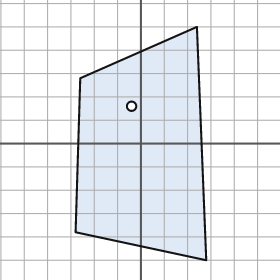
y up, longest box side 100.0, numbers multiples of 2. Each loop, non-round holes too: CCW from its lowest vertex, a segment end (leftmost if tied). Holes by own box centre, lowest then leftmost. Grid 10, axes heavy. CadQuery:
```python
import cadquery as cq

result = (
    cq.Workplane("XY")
    .moveTo(28.0, -50.0)
    .lineTo(24.0, 50.0)
    .lineTo(-26.0, 28.0)
    .lineTo(-28.0, -38.0)
    .close()
    .moveTo(-4.0, 16.0)
    .circle(2.0)
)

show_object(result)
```